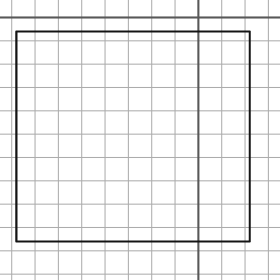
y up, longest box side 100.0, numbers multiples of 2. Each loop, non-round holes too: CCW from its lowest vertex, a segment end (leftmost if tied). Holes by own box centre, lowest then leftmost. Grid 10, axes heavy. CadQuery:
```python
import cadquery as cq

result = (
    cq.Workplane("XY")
    .moveTo(-78.0, -96.0)
    .lineTo(22.0, -96.0)
    .lineTo(22.0, -6.0)
    .lineTo(-78.0, -6.0)
    .close()
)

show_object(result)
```